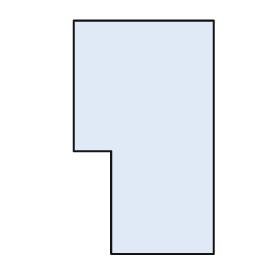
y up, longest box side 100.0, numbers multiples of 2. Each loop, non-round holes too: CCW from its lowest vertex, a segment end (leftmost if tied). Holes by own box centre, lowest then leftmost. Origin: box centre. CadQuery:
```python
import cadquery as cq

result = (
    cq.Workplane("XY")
    .moveTo(-14.0, -50.0)
    .lineTo(30.0, -50.0)
    .lineTo(30.0, 50.0)
    .lineTo(-30.0, 50.0)
    .lineTo(-30.0, -6.0)
    .lineTo(-14.0, -6.0)
    .close()
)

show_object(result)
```